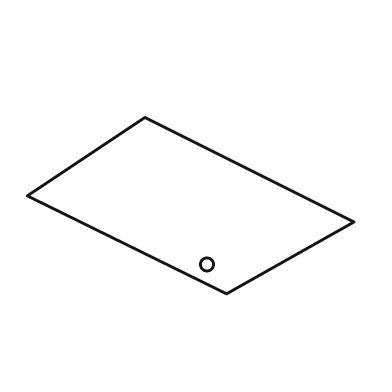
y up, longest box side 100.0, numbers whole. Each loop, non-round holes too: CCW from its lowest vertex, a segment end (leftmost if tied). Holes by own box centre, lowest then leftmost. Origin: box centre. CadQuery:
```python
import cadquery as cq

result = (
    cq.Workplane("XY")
    .moveTo(11.0, -27.0)
    .lineTo(50.0, -5.0)
    .lineTo(-14.0, 27.0)
    .lineTo(-50.0, 3.0)
    .close()
    .moveTo(5.0, -18.0)
    .circle(2.0)
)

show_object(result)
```